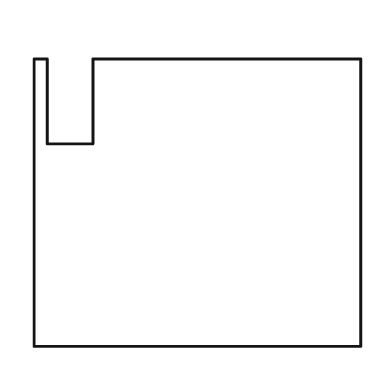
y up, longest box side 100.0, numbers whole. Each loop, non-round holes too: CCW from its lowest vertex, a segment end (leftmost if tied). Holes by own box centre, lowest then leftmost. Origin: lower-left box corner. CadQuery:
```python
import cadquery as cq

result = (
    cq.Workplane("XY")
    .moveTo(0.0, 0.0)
    .lineTo(100.0, 0.0)
    .lineTo(100.0, 88.0)
    .lineTo(18.0, 88.0)
    .lineTo(18.0, 62.0)
    .lineTo(4.0, 62.0)
    .lineTo(4.0, 88.0)
    .lineTo(0.0, 88.0)
    .close()
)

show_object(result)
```